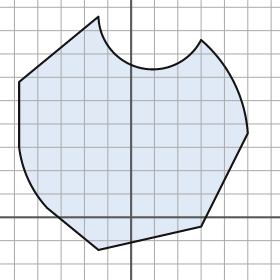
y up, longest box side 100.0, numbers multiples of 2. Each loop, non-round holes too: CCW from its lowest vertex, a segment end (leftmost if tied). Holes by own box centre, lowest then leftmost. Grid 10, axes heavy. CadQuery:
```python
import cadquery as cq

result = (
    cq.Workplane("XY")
    .moveTo(-14.0, -14.0)
    .lineTo(30.0, -4.0)
    .lineTo(50.0, 36.0)
    .threePointArc((44.0, 58.0), (30.0, 76.0))
    .threePointArc((4.0, 64.0), (-14.0, 86.0))
    .lineTo(-48.0, 58.0)
    .lineTo(-48.0, 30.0)
    .threePointArc((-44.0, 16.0), (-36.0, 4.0))
    .close()
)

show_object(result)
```